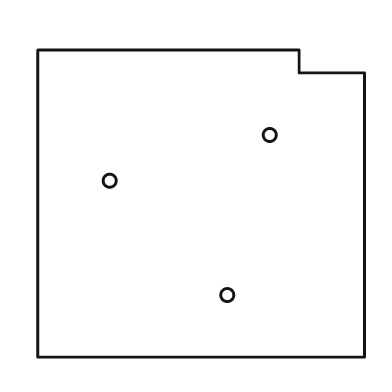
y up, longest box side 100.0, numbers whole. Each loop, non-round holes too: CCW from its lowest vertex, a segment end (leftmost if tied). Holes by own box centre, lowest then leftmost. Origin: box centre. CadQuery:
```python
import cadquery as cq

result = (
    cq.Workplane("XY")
    .moveTo(-50.0, -47.0)
    .lineTo(50.0, -47.0)
    .lineTo(50.0, 40.0)
    .lineTo(30.0, 40.0)
    .lineTo(30.0, 47.0)
    .lineTo(-50.0, 47.0)
    .close()
    .moveTo(8.0, -28.0)
    .circle(2.0)
    .moveTo(-28.0, 7.0)
    .circle(2.0)
    .moveTo(21.0, 21.0)
    .circle(2.0)
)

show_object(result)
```